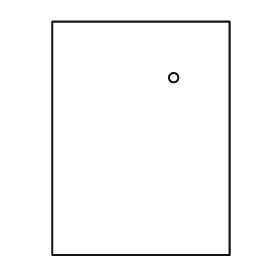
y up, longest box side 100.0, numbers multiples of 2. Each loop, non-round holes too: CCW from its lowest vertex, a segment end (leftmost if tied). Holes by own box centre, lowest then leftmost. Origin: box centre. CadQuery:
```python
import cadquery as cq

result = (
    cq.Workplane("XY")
    .moveTo(-38.0, -50.0)
    .lineTo(38.0, -50.0)
    .lineTo(38.0, 50.0)
    .lineTo(-38.0, 50.0)
    .close()
    .moveTo(14.0, 26.0)
    .circle(2.0)
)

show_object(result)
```